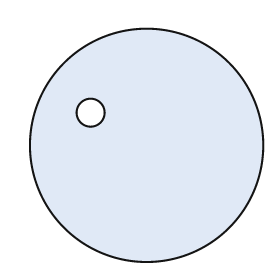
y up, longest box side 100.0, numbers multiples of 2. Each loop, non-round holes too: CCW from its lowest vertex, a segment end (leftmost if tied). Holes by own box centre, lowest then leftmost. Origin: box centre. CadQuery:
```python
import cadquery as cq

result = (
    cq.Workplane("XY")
    .moveTo(0.0, 0.0)
    .circle(50.0)
    .moveTo(-24.0, 14.0)
    .circle(6.0)
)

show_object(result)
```